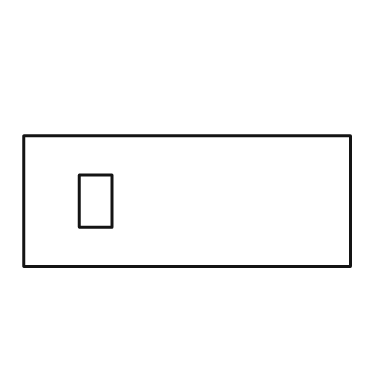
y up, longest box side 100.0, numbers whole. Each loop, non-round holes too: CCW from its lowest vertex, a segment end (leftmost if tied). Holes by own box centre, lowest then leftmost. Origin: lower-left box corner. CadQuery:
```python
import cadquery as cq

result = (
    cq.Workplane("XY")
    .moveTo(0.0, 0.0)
    .lineTo(100.0, 0.0)
    .lineTo(100.0, 40.0)
    .lineTo(0.0, 40.0)
    .close()
    .moveTo(17.0, 12.0)
    .lineTo(27.0, 12.0)
    .lineTo(27.0, 28.0)
    .lineTo(17.0, 28.0)
    .close()
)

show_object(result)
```